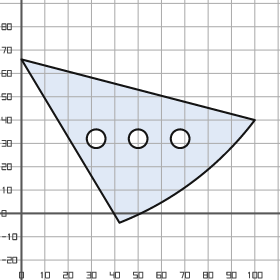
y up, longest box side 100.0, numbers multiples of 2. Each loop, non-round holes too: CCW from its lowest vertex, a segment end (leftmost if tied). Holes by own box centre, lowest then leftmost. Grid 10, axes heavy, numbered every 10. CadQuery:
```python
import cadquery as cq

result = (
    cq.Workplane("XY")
    .moveTo(42.0, -4.0)
    .threePointArc((74.0, 14.0), (100.0, 40.0))
    .lineTo(0.0, 66.0)
    .close()
    .moveTo(32.0, 32.0)
    .circle(4.0)
    .moveTo(50.0, 32.0)
    .circle(4.0)
    .moveTo(68.0, 32.0)
    .circle(4.0)
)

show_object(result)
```